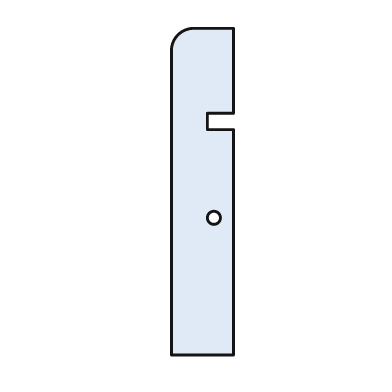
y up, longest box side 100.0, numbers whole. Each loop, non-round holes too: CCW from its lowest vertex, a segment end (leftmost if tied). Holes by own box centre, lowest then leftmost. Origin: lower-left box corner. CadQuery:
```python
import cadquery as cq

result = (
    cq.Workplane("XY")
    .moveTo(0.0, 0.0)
    .lineTo(19.0, 0.0)
    .lineTo(19.0, 69.0)
    .lineTo(11.0, 69.0)
    .lineTo(11.0, 74.0)
    .lineTo(19.0, 74.0)
    .lineTo(19.0, 100.0)
    .lineTo(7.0, 100.0)
    .threePointArc((2.0, 98.0), (0.0, 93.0))
    .close()
    .moveTo(13.0, 42.0)
    .circle(2.0)
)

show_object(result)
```